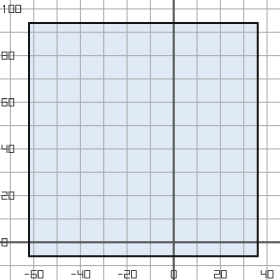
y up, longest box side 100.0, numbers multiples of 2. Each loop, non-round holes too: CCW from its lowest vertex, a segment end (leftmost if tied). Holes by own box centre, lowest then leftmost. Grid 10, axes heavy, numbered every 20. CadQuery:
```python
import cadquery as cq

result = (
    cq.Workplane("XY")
    .moveTo(-62.0, -6.0)
    .lineTo(36.0, -6.0)
    .lineTo(36.0, 94.0)
    .lineTo(-62.0, 94.0)
    .close()
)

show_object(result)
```